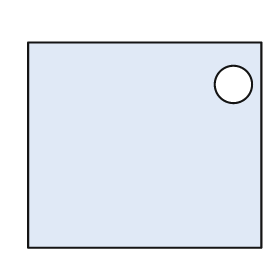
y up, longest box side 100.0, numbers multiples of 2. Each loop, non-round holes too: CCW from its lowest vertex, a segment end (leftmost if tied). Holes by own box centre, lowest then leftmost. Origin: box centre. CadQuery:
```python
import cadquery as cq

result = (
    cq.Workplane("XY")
    .moveTo(-50.0, -44.0)
    .lineTo(50.0, -44.0)
    .lineTo(50.0, 44.0)
    .lineTo(-50.0, 44.0)
    .close()
    .moveTo(38.0, 26.0)
    .circle(8.0)
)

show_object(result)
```